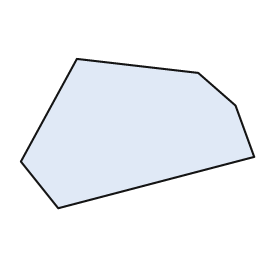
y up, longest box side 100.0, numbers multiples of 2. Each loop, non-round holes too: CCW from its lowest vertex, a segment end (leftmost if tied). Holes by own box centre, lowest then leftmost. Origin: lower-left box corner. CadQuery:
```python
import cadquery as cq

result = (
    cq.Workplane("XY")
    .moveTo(16.0, 0.0)
    .lineTo(100.0, 22.0)
    .lineTo(92.0, 44.0)
    .lineTo(76.0, 58.0)
    .lineTo(24.0, 64.0)
    .lineTo(0.0, 20.0)
    .close()
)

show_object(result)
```